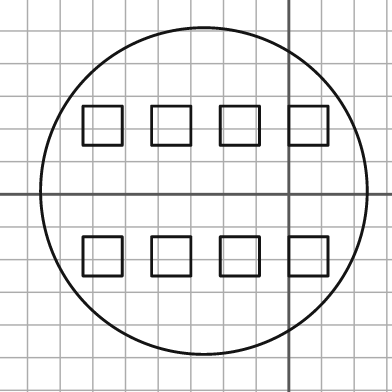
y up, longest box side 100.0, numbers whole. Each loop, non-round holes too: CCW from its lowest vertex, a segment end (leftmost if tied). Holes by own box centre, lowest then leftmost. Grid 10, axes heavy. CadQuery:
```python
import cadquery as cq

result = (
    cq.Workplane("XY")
    .moveTo(-26.0, 1.0)
    .circle(50.0)
    .moveTo(-63.0, -25.0)
    .lineTo(-51.0, -25.0)
    .lineTo(-51.0, -13.0)
    .lineTo(-63.0, -13.0)
    .close()
    .moveTo(-42.0, -25.0)
    .lineTo(-30.0, -25.0)
    .lineTo(-30.0, -13.0)
    .lineTo(-42.0, -13.0)
    .close()
    .moveTo(-21.0, -25.0)
    .lineTo(-9.0, -25.0)
    .lineTo(-9.0, -13.0)
    .lineTo(-21.0, -13.0)
    .close()
    .moveTo(0.0, -25.0)
    .lineTo(12.0, -25.0)
    .lineTo(12.0, -13.0)
    .lineTo(0.0, -13.0)
    .close()
    .moveTo(-63.0, 15.0)
    .lineTo(-51.0, 15.0)
    .lineTo(-51.0, 27.0)
    .lineTo(-63.0, 27.0)
    .close()
    .moveTo(-42.0, 15.0)
    .lineTo(-30.0, 15.0)
    .lineTo(-30.0, 27.0)
    .lineTo(-42.0, 27.0)
    .close()
    .moveTo(-21.0, 15.0)
    .lineTo(-9.0, 15.0)
    .lineTo(-9.0, 27.0)
    .lineTo(-21.0, 27.0)
    .close()
    .moveTo(0.0, 15.0)
    .lineTo(12.0, 15.0)
    .lineTo(12.0, 27.0)
    .lineTo(0.0, 27.0)
    .close()
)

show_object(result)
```